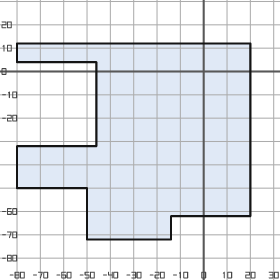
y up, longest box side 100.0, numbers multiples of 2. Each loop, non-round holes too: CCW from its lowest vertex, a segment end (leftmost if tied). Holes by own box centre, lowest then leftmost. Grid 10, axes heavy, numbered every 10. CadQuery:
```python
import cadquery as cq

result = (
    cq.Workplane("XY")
    .moveTo(-50.0, -72.0)
    .lineTo(-14.0, -72.0)
    .lineTo(-14.0, -62.0)
    .lineTo(20.0, -62.0)
    .lineTo(20.0, 12.0)
    .lineTo(-80.0, 12.0)
    .lineTo(-80.0, 4.0)
    .lineTo(-46.0, 4.0)
    .lineTo(-46.0, -32.0)
    .lineTo(-80.0, -32.0)
    .lineTo(-80.0, -50.0)
    .lineTo(-50.0, -50.0)
    .close()
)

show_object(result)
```